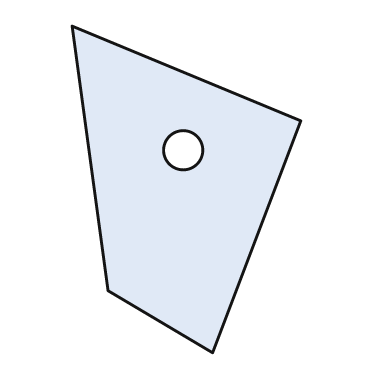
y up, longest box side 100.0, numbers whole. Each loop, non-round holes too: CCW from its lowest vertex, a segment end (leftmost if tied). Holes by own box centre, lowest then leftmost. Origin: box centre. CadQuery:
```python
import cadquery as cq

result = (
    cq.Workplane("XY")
    .moveTo(8.0, -50.0)
    .lineTo(35.0, 21.0)
    .lineTo(-35.0, 50.0)
    .lineTo(-24.0, -31.0)
    .close()
    .moveTo(-1.0, 12.0)
    .circle(6.0)
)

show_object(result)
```